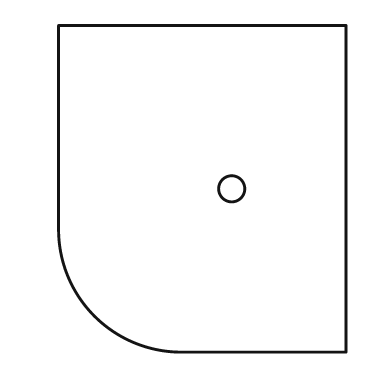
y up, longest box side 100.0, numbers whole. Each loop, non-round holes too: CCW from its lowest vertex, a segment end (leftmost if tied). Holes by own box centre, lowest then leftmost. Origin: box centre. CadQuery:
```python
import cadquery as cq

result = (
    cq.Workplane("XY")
    .moveTo(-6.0, -50.0)
    .lineTo(44.0, -50.0)
    .lineTo(44.0, 50.0)
    .lineTo(-44.0, 50.0)
    .lineTo(-44.0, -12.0)
    .threePointArc((-33.0, -39.0), (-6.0, -50.0))
    .close()
    .moveTo(9.0, 0.0)
    .circle(4.0)
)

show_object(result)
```